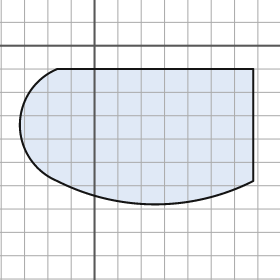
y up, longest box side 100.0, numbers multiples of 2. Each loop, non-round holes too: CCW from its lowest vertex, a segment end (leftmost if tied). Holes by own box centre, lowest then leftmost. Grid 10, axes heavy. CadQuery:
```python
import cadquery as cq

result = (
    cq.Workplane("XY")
    .moveTo(-16.0, -58.0)
    .threePointArc((26.0, -68.0), (68.0, -58.0))
    .lineTo(68.0, -10.0)
    .lineTo(-16.0, -10.0)
    .threePointArc((-32.0, -34.0), (-16.0, -58.0))
    .close()
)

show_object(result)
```